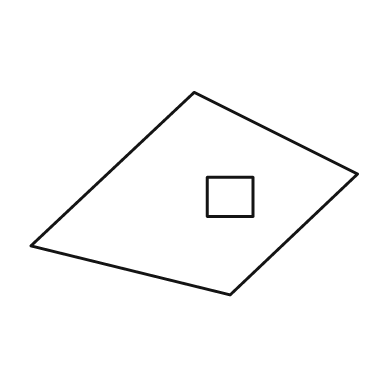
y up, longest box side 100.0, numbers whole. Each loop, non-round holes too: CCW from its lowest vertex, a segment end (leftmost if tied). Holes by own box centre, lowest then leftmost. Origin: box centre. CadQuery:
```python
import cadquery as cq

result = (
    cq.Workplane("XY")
    .moveTo(11.0, -31.0)
    .lineTo(50.0, 6.0)
    .lineTo(0.0, 31.0)
    .lineTo(-50.0, -16.0)
    .close()
    .moveTo(4.0, -7.0)
    .lineTo(18.0, -7.0)
    .lineTo(18.0, 5.0)
    .lineTo(4.0, 5.0)
    .close()
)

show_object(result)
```